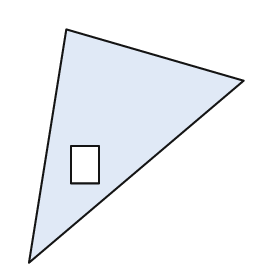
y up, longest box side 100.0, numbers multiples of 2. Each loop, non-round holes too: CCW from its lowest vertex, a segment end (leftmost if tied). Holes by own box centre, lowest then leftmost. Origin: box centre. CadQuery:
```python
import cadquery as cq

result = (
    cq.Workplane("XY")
    .moveTo(-46.0, -50.0)
    .lineTo(46.0, 28.0)
    .lineTo(-30.0, 50.0)
    .close()
    .moveTo(-28.0, -16.0)
    .lineTo(-16.0, -16.0)
    .lineTo(-16.0, 0.0)
    .lineTo(-28.0, 0.0)
    .close()
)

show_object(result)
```